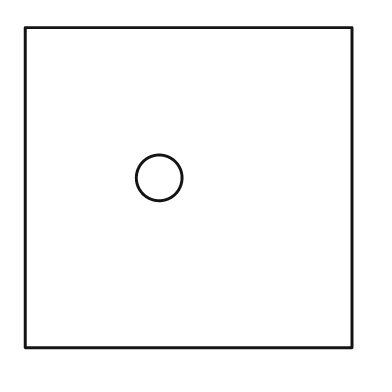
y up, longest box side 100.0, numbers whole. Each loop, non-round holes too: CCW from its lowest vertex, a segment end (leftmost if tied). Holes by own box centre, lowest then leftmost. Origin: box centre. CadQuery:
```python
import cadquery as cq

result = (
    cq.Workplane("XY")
    .moveTo(-50.0, -49.0)
    .lineTo(50.0, -49.0)
    .lineTo(50.0, 49.0)
    .lineTo(-50.0, 49.0)
    .close()
    .moveTo(-9.0, 3.0)
    .circle(7.0)
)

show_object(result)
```